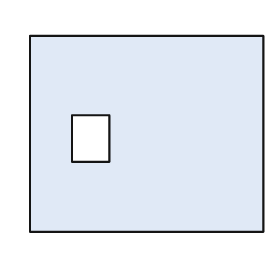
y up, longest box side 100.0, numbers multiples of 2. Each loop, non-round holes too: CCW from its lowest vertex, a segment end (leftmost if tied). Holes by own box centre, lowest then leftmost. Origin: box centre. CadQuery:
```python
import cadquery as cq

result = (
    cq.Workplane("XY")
    .moveTo(-50.0, -42.0)
    .lineTo(50.0, -42.0)
    .lineTo(50.0, 42.0)
    .lineTo(-50.0, 42.0)
    .close()
    .moveTo(-32.0, -12.0)
    .lineTo(-16.0, -12.0)
    .lineTo(-16.0, 8.0)
    .lineTo(-32.0, 8.0)
    .close()
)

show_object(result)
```